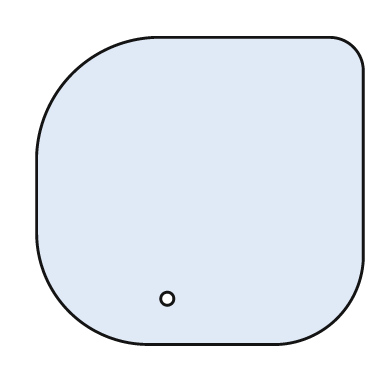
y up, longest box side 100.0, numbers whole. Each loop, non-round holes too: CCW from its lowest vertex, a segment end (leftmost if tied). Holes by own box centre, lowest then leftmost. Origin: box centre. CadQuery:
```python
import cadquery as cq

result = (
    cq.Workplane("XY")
    .moveTo(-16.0, -47.0)
    .lineTo(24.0, -47.0)
    .threePointArc((42.0, -39.0), (50.0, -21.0))
    .lineTo(50.0, 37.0)
    .threePointArc((47.0, 44.0), (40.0, 47.0))
    .lineTo(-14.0, 47.0)
    .threePointArc((-39.0, 36.0), (-50.0, 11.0))
    .lineTo(-50.0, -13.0)
    .threePointArc((-40.0, -37.0), (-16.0, -47.0))
    .close()
    .moveTo(-10.0, -33.0)
    .circle(2.0)
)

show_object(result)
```